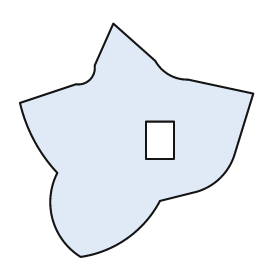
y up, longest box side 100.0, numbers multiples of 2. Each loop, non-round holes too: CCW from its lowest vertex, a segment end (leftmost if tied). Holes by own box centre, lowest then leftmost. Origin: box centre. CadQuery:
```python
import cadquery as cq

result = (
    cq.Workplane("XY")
    .moveTo(-24.0, -50.0)
    .threePointArc((-4.0, -42.0), (10.0, -26.0))
    .lineTo(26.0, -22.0)
    .threePointArc((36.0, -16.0), (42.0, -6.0))
    .lineTo(50.0, 20.0)
    .lineTo(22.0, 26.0)
    .threePointArc((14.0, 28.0), (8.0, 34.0))
    .lineTo(-10.0, 50.0)
    .lineTo(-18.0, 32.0)
    .threePointArc((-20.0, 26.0), (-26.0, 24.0))
    .lineTo(-50.0, 16.0)
    .threePointArc((-44.0, 0.0), (-34.0, -14.0))
    .threePointArc((-36.0, -34.0), (-24.0, -50.0))
    .close()
    .moveTo(4.0, -8.0)
    .lineTo(16.0, -8.0)
    .lineTo(16.0, 8.0)
    .lineTo(4.0, 8.0)
    .close()
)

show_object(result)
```